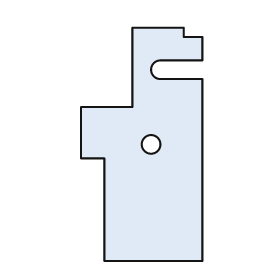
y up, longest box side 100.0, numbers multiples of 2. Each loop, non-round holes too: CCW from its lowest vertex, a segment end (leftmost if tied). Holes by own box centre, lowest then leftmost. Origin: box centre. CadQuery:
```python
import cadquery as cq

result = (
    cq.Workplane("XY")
    .moveTo(-16.0, -50.0)
    .lineTo(26.0, -50.0)
    .lineTo(26.0, 28.0)
    .lineTo(8.0, 28.0)
    .threePointArc((4.0, 32.0), (8.0, 36.0))
    .lineTo(26.0, 36.0)
    .lineTo(26.0, 46.0)
    .lineTo(18.0, 46.0)
    .lineTo(18.0, 50.0)
    .lineTo(-4.0, 50.0)
    .lineTo(-4.0, 16.0)
    .lineTo(-26.0, 16.0)
    .lineTo(-26.0, -6.0)
    .lineTo(-16.0, -6.0)
    .close()
    .moveTo(4.0, 0.0)
    .circle(4.0)
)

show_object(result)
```